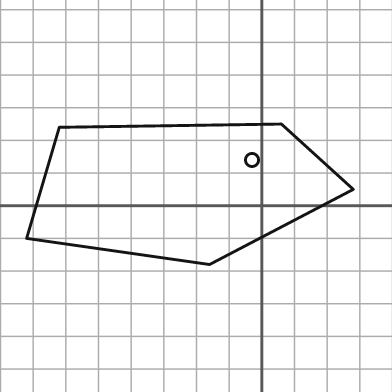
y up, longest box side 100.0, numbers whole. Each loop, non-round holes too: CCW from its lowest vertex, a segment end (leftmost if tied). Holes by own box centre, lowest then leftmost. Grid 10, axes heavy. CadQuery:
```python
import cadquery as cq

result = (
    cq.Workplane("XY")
    .moveTo(-16.0, -18.0)
    .lineTo(28.0, 5.0)
    .lineTo(6.0, 25.0)
    .lineTo(-62.0, 24.0)
    .lineTo(-72.0, -10.0)
    .close()
    .moveTo(-3.0, 14.0)
    .circle(2.0)
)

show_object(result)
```